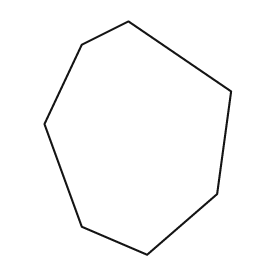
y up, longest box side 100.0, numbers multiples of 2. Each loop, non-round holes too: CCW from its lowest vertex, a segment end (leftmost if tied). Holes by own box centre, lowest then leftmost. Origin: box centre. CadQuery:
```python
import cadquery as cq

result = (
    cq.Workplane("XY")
    .moveTo(4.0, -50.0)
    .lineTo(34.0, -24.0)
    .lineTo(40.0, 20.0)
    .lineTo(-4.0, 50.0)
    .lineTo(-24.0, 40.0)
    .lineTo(-40.0, 6.0)
    .lineTo(-24.0, -38.0)
    .close()
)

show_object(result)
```